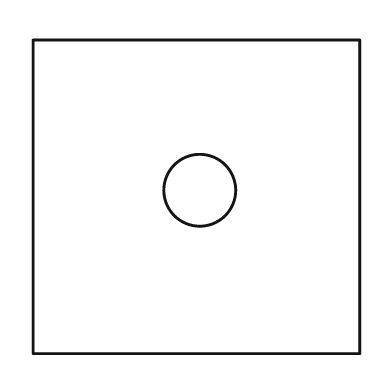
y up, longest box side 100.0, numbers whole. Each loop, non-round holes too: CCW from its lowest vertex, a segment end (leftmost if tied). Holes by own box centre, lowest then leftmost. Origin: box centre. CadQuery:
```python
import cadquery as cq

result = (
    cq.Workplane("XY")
    .moveTo(-50.0, -48.0)
    .lineTo(50.0, -48.0)
    .lineTo(50.0, 48.0)
    .lineTo(-50.0, 48.0)
    .close()
    .moveTo(1.0, 2.0)
    .circle(11.0)
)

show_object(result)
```